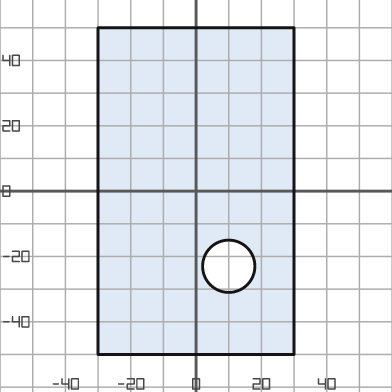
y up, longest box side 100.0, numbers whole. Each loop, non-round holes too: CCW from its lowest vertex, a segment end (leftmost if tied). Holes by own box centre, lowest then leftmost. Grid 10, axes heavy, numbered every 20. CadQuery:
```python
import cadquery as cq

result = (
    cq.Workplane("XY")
    .moveTo(-30.0, -50.0)
    .lineTo(30.0, -50.0)
    .lineTo(30.0, 50.0)
    .lineTo(-30.0, 50.0)
    .close()
    .moveTo(10.0, -23.0)
    .circle(8.0)
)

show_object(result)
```